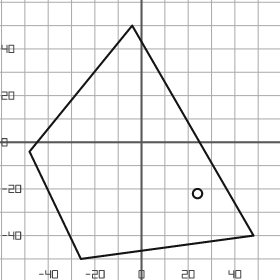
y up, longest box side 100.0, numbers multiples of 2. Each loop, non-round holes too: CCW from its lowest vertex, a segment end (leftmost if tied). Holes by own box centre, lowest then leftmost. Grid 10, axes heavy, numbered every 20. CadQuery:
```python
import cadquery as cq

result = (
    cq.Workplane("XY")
    .moveTo(-26.0, -50.0)
    .lineTo(48.0, -40.0)
    .lineTo(-4.0, 50.0)
    .lineTo(-48.0, -4.0)
    .close()
    .moveTo(24.0, -22.0)
    .circle(2.0)
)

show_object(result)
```